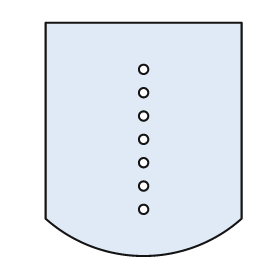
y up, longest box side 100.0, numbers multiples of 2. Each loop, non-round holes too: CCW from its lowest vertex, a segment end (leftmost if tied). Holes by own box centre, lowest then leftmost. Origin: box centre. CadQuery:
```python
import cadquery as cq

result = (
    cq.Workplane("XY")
    .moveTo(-42.0, -34.0)
    .threePointArc((0.0, -50.0), (42.0, -34.0))
    .lineTo(42.0, 50.0)
    .lineTo(-42.0, 50.0)
    .close()
    .moveTo(0.0, -30.0)
    .circle(2.0)
    .moveTo(0.0, -20.0)
    .circle(2.0)
    .moveTo(0.0, -10.0)
    .circle(2.0)
    .moveTo(0.0, 0.0)
    .circle(2.0)
    .moveTo(0.0, 10.0)
    .circle(2.0)
    .moveTo(0.0, 20.0)
    .circle(2.0)
    .moveTo(0.0, 30.0)
    .circle(2.0)
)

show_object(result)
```